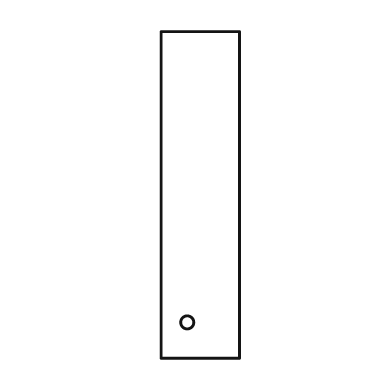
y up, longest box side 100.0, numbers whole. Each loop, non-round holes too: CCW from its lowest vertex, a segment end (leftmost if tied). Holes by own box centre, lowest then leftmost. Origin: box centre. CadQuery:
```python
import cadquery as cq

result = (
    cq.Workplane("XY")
    .moveTo(-12.0, -50.0)
    .lineTo(12.0, -50.0)
    .lineTo(12.0, 50.0)
    .lineTo(-12.0, 50.0)
    .close()
    .moveTo(-4.0, -39.0)
    .circle(2.0)
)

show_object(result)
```